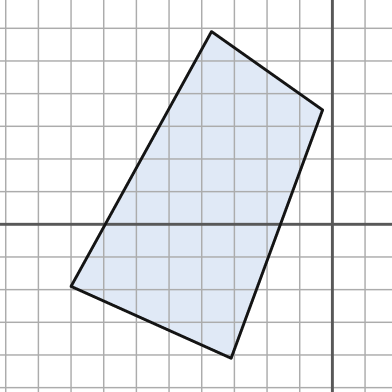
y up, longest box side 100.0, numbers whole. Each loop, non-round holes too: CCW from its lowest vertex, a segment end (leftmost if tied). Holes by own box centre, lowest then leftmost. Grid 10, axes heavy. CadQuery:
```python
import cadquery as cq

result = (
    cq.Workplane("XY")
    .moveTo(-31.0, -41.0)
    .lineTo(-3.0, 35.0)
    .lineTo(-37.0, 59.0)
    .lineTo(-80.0, -19.0)
    .close()
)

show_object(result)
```